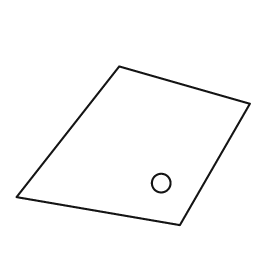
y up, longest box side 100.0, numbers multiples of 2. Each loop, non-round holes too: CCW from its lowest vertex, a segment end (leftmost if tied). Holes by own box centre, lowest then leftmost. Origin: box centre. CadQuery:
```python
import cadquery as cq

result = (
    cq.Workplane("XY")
    .moveTo(20.0, -34.0)
    .lineTo(50.0, 18.0)
    .lineTo(-6.0, 34.0)
    .lineTo(-50.0, -22.0)
    .close()
    .moveTo(12.0, -16.0)
    .circle(4.0)
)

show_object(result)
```